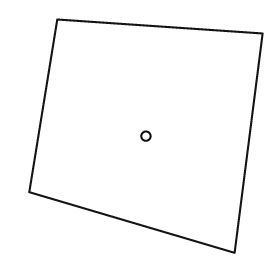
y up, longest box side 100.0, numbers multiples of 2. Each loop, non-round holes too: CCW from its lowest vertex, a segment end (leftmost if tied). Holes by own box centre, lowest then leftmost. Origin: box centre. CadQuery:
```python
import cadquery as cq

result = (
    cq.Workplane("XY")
    .moveTo(38.0, -50.0)
    .lineTo(50.0, 44.0)
    .lineTo(-38.0, 50.0)
    .lineTo(-50.0, -24.0)
    .close()
    .moveTo(0.0, 0.0)
    .circle(2.0)
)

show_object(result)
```